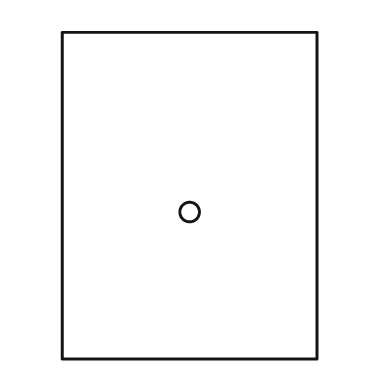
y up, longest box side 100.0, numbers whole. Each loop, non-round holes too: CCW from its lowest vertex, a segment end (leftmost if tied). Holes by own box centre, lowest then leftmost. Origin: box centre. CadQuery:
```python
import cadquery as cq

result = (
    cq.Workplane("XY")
    .moveTo(-39.0, -50.0)
    .lineTo(39.0, -50.0)
    .lineTo(39.0, 50.0)
    .lineTo(-39.0, 50.0)
    .close()
    .moveTo(0.0, -5.0)
    .circle(3.0)
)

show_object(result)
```